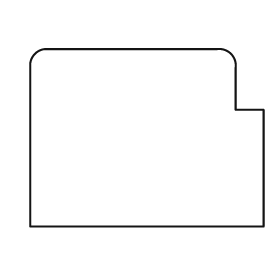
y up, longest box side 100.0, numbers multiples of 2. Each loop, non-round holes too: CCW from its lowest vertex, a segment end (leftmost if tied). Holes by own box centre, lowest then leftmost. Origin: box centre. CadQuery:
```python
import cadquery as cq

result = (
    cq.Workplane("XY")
    .moveTo(-50.0, -38.0)
    .lineTo(50.0, -38.0)
    .lineTo(50.0, 12.0)
    .lineTo(38.0, 12.0)
    .lineTo(38.0, 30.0)
    .threePointArc((36.0, 36.0), (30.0, 38.0))
    .lineTo(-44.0, 38.0)
    .threePointArc((-48.0, 36.0), (-50.0, 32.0))
    .close()
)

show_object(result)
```